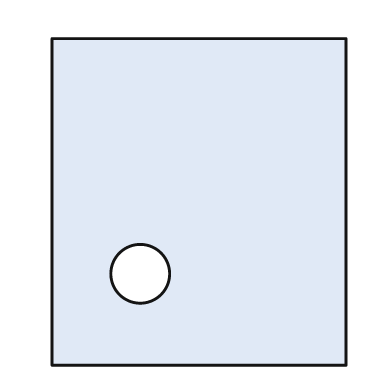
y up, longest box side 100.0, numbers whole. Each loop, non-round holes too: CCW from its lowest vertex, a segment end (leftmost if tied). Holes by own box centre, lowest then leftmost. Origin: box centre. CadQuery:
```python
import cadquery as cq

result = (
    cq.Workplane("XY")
    .moveTo(-45.0, -50.0)
    .lineTo(45.0, -50.0)
    .lineTo(45.0, 50.0)
    .lineTo(-45.0, 50.0)
    .close()
    .moveTo(-18.0, -22.0)
    .circle(9.0)
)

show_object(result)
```